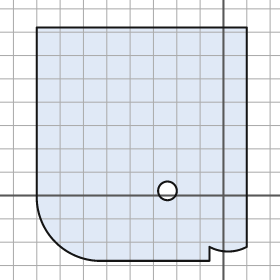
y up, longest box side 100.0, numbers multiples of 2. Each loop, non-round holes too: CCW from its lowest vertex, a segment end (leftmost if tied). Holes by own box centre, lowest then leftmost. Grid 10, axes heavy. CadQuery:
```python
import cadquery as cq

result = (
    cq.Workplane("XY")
    .moveTo(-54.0, -28.0)
    .lineTo(-6.0, -28.0)
    .lineTo(-6.0, -22.0)
    .threePointArc((2.0, -24.0), (10.0, -22.0))
    .lineTo(10.0, 72.0)
    .lineTo(-80.0, 72.0)
    .lineTo(-80.0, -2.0)
    .threePointArc((-72.0, -20.0), (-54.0, -28.0))
    .close()
    .moveTo(-24.0, 2.0)
    .circle(4.0)
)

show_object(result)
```